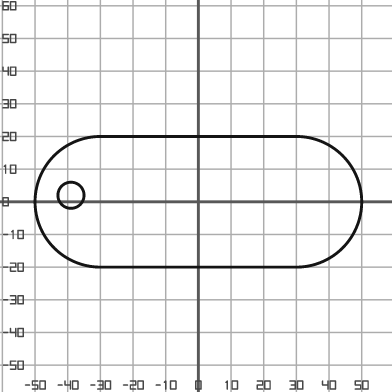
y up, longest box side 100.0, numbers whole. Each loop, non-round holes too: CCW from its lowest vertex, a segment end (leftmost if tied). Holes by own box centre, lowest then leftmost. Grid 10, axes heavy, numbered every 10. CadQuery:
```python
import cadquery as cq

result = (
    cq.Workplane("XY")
    .moveTo(-30.0, -20.0)
    .lineTo(30.0, -20.0)
    .threePointArc((50.0, 0.0), (30.0, 20.0))
    .lineTo(-30.0, 20.0)
    .threePointArc((-50.0, 0.0), (-30.0, -20.0))
    .close()
    .moveTo(-39.0, 2.0)
    .circle(4.0)
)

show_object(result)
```